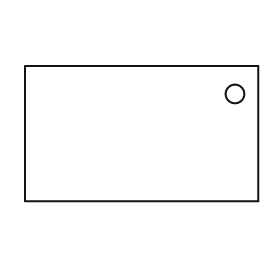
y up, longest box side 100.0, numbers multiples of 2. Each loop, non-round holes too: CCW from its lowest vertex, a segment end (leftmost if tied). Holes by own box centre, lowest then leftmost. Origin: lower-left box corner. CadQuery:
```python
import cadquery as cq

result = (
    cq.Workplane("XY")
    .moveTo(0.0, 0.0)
    .lineTo(100.0, 0.0)
    .lineTo(100.0, 58.0)
    .lineTo(0.0, 58.0)
    .close()
    .moveTo(90.0, 46.0)
    .circle(4.0)
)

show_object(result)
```